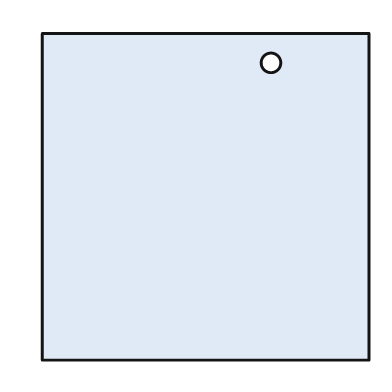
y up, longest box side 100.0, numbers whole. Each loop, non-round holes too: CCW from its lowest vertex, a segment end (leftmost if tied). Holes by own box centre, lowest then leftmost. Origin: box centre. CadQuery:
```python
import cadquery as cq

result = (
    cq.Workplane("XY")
    .moveTo(-50.0, -50.0)
    .lineTo(50.0, -50.0)
    .lineTo(50.0, 50.0)
    .lineTo(-50.0, 50.0)
    .close()
    .moveTo(20.0, 41.0)
    .circle(3.0)
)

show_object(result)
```